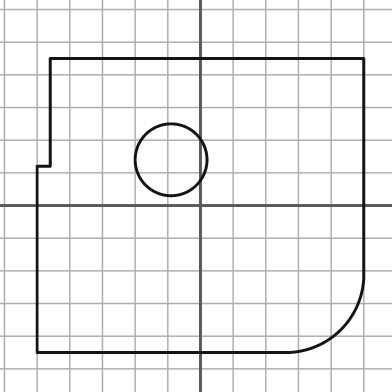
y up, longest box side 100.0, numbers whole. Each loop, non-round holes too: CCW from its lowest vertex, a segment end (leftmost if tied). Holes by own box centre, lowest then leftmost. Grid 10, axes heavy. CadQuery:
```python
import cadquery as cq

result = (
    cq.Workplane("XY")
    .moveTo(-50.0, -45.0)
    .lineTo(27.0, -45.0)
    .threePointArc((43.0, -38.0), (50.0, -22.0))
    .lineTo(50.0, 45.0)
    .lineTo(-46.0, 45.0)
    .lineTo(-46.0, 12.0)
    .lineTo(-50.0, 12.0)
    .close()
    .moveTo(-9.0, 14.0)
    .circle(11.0)
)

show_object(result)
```